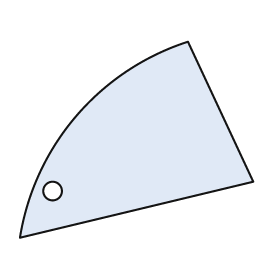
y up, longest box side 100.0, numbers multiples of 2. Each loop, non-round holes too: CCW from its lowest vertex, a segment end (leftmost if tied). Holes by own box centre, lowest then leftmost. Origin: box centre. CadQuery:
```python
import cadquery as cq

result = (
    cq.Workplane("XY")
    .moveTo(-50.0, -42.0)
    .lineTo(50.0, -18.0)
    .lineTo(22.0, 42.0)
    .threePointArc((-26.0, 10.0), (-50.0, -42.0))
    .close()
    .moveTo(-36.0, -22.0)
    .circle(4.0)
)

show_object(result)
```